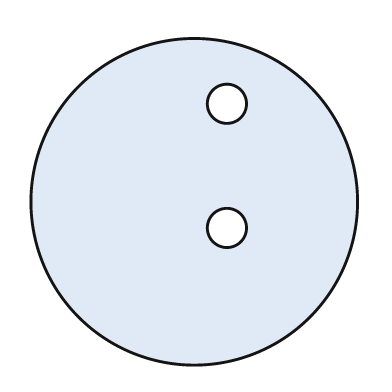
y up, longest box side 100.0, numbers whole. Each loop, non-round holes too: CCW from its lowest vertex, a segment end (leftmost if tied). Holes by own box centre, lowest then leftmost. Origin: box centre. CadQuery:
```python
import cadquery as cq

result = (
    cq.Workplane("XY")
    .moveTo(0.0, 0.0)
    .circle(50.0)
    .moveTo(10.0, -8.0)
    .circle(6.0)
    .moveTo(10.0, 30.0)
    .circle(6.0)
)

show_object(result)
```